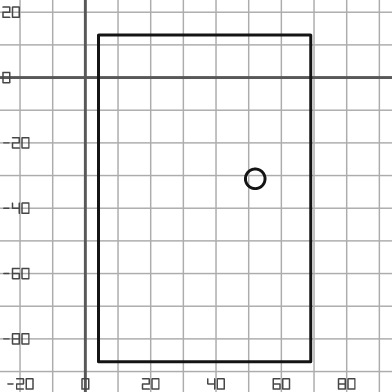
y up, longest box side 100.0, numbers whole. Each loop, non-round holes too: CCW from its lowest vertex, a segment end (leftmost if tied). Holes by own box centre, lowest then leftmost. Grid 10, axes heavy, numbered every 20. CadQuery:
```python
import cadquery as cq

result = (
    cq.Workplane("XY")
    .moveTo(4.0, -87.0)
    .lineTo(69.0, -87.0)
    .lineTo(69.0, 13.0)
    .lineTo(4.0, 13.0)
    .close()
    .moveTo(52.0, -31.0)
    .circle(3.0)
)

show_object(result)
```